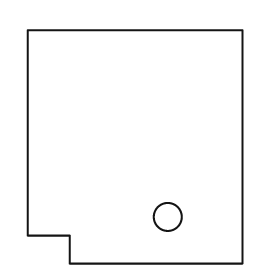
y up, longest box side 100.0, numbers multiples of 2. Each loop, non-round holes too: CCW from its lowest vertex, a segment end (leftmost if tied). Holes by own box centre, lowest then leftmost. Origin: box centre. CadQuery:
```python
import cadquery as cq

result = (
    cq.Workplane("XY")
    .moveTo(-28.0, -50.0)
    .lineTo(46.0, -50.0)
    .lineTo(46.0, 50.0)
    .lineTo(-46.0, 50.0)
    .lineTo(-46.0, -38.0)
    .lineTo(-28.0, -38.0)
    .close()
    .moveTo(14.0, -30.0)
    .circle(6.0)
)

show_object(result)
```